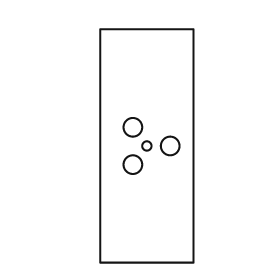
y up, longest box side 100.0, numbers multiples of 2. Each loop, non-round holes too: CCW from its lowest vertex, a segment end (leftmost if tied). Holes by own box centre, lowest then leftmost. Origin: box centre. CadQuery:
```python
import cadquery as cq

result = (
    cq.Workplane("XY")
    .moveTo(-20.0, -50.0)
    .lineTo(20.0, -50.0)
    .lineTo(20.0, 50.0)
    .lineTo(-20.0, 50.0)
    .close()
    .moveTo(-6.0, -8.0)
    .circle(4.0)
    .moveTo(0.0, 0.0)
    .circle(2.0)
    .moveTo(10.0, 0.0)
    .circle(4.0)
    .moveTo(-6.0, 8.0)
    .circle(4.0)
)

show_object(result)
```